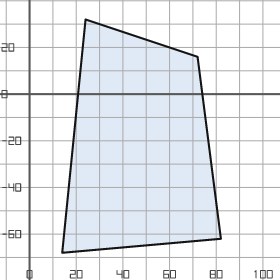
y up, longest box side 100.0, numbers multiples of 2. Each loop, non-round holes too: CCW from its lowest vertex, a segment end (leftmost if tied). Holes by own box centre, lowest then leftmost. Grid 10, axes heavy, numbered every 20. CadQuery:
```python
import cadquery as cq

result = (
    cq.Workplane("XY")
    .moveTo(14.0, -68.0)
    .lineTo(82.0, -62.0)
    .lineTo(72.0, 16.0)
    .lineTo(24.0, 32.0)
    .close()
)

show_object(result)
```